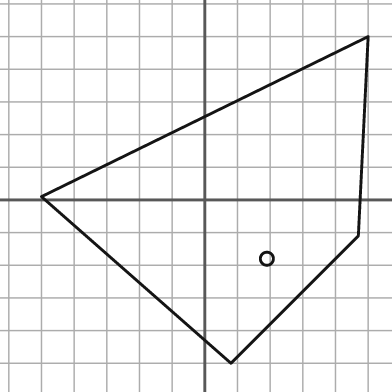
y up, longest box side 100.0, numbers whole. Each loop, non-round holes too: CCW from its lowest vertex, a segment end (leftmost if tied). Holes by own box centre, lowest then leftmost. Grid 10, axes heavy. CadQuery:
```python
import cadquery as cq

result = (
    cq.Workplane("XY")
    .moveTo(8.0, -50.0)
    .lineTo(47.0, -11.0)
    .lineTo(50.0, 50.0)
    .lineTo(-50.0, 1.0)
    .close()
    .moveTo(19.0, -18.0)
    .circle(2.0)
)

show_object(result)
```